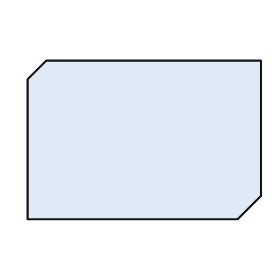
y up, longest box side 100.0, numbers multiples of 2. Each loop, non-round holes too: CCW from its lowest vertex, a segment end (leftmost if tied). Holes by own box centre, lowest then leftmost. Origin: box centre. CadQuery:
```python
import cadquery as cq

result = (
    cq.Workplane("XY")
    .moveTo(-50.0, -34.0)
    .lineTo(40.0, -34.0)
    .lineTo(50.0, -24.0)
    .lineTo(50.0, 34.0)
    .lineTo(-42.0, 34.0)
    .lineTo(-50.0, 26.0)
    .close()
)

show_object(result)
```